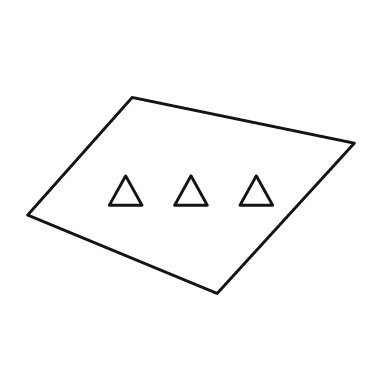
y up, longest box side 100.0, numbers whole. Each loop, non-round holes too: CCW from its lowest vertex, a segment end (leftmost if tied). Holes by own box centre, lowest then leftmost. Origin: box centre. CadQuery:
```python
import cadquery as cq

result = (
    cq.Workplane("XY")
    .moveTo(8.0, -30.0)
    .lineTo(50.0, 16.0)
    .lineTo(-18.0, 30.0)
    .lineTo(-50.0, -6.0)
    .close()
    .moveTo(-25.0, -3.0)
    .lineTo(-15.0, -3.0)
    .lineTo(-20.0, 6.0)
    .close()
    .moveTo(-5.0, -3.0)
    .lineTo(5.0, -3.0)
    .lineTo(0.0, 6.0)
    .close()
    .moveTo(15.0, -3.0)
    .lineTo(25.0, -3.0)
    .lineTo(20.0, 6.0)
    .close()
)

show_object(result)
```